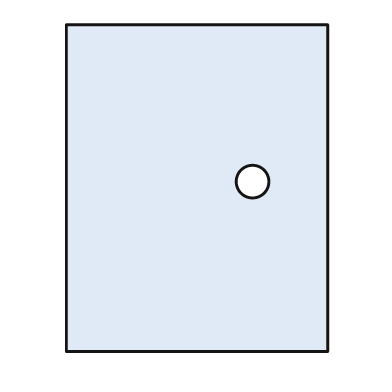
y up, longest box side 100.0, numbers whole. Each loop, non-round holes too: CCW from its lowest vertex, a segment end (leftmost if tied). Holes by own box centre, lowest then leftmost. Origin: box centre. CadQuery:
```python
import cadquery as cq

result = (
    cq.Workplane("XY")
    .moveTo(-40.0, -50.0)
    .lineTo(40.0, -50.0)
    .lineTo(40.0, 50.0)
    .lineTo(-40.0, 50.0)
    .close()
    .moveTo(17.0, 2.0)
    .circle(5.0)
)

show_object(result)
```